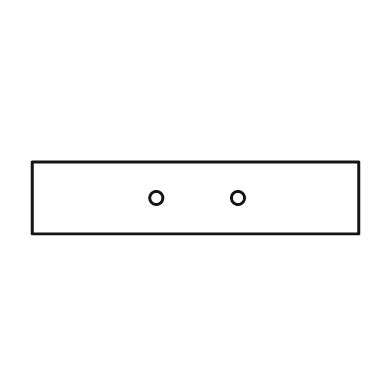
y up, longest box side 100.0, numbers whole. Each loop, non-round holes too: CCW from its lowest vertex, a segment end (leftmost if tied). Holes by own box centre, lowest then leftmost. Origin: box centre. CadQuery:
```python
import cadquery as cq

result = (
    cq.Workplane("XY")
    .moveTo(-50.0, -11.0)
    .lineTo(50.0, -11.0)
    .lineTo(50.0, 11.0)
    .lineTo(-50.0, 11.0)
    .close()
    .moveTo(-12.0, 0.0)
    .circle(2.0)
    .moveTo(13.0, 0.0)
    .circle(2.0)
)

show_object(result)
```